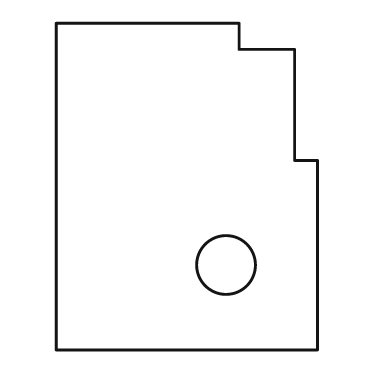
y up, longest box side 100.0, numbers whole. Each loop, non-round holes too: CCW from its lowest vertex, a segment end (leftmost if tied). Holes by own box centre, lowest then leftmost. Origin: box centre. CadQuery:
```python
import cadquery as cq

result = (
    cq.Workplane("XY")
    .moveTo(-40.0, -50.0)
    .lineTo(40.0, -50.0)
    .lineTo(40.0, 8.0)
    .lineTo(33.0, 8.0)
    .lineTo(33.0, 42.0)
    .lineTo(16.0, 42.0)
    .lineTo(16.0, 50.0)
    .lineTo(-40.0, 50.0)
    .close()
    .moveTo(12.0, -24.0)
    .circle(9.0)
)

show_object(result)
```